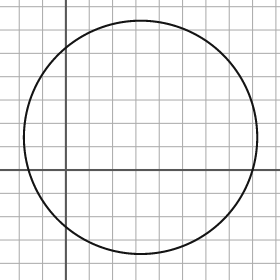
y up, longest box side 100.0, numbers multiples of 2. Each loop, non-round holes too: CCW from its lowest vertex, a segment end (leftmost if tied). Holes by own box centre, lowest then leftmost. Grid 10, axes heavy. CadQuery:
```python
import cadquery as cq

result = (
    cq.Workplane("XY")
    .moveTo(32.0, 14.0)
    .circle(50.0)
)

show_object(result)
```